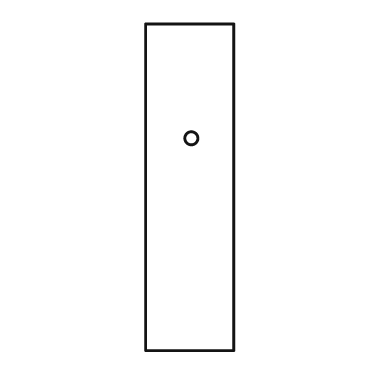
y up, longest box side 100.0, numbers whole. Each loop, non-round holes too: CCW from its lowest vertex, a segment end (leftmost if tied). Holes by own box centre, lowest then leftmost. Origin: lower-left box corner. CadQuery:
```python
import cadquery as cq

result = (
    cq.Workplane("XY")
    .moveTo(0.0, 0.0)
    .lineTo(27.0, 0.0)
    .lineTo(27.0, 100.0)
    .lineTo(0.0, 100.0)
    .close()
    .moveTo(14.0, 65.0)
    .circle(2.0)
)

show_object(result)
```